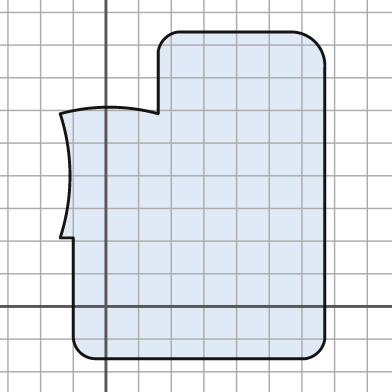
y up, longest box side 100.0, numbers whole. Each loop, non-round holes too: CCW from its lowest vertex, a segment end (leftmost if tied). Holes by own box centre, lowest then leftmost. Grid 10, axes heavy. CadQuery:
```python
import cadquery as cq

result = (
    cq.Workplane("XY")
    .moveTo(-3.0, -16.0)
    .lineTo(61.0, -16.0)
    .threePointArc((65.0, -14.0), (67.0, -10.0))
    .lineTo(67.0, 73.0)
    .threePointArc((64.0, 81.0), (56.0, 84.0))
    .lineTo(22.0, 84.0)
    .threePointArc((18.0, 82.0), (16.0, 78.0))
    .lineTo(16.0, 59.0)
    .threePointArc((1.0, 61.0), (-14.0, 59.0))
    .threePointArc((-11.0, 40.0), (-14.0, 21.0))
    .lineTo(-10.0, 21.0)
    .lineTo(-10.0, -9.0)
    .threePointArc((-8.0, -14.0), (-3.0, -16.0))
    .close()
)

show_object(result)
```